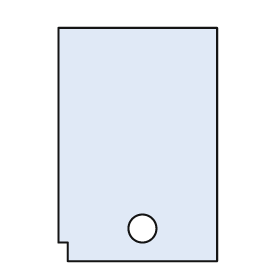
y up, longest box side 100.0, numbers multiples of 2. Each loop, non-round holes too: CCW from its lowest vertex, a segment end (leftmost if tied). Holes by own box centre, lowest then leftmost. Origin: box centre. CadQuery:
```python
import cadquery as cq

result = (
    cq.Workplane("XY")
    .moveTo(-30.0, -50.0)
    .lineTo(34.0, -50.0)
    .lineTo(34.0, 50.0)
    .lineTo(-34.0, 50.0)
    .lineTo(-34.0, -42.0)
    .lineTo(-30.0, -42.0)
    .close()
    .moveTo(2.0, -36.0)
    .circle(6.0)
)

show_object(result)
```